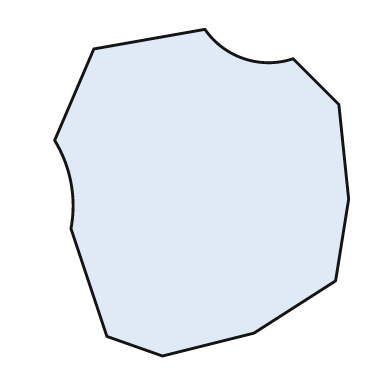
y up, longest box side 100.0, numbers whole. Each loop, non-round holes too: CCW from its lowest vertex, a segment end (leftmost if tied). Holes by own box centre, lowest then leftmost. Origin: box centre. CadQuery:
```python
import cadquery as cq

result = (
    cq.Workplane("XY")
    .moveTo(-12.0, -50.0)
    .lineTo(16.0, -43.0)
    .lineTo(41.0, -27.0)
    .lineTo(45.0, -2.0)
    .lineTo(42.0, 27.0)
    .lineTo(28.0, 41.0)
    .threePointArc((13.0, 41.0), (1.0, 50.0))
    .lineTo(-33.0, 44.0)
    .lineTo(-45.0, 16.0)
    .threePointArc((-40.0, 3.0), (-40.0, -11.0))
    .lineTo(-29.0, -44.0)
    .close()
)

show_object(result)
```